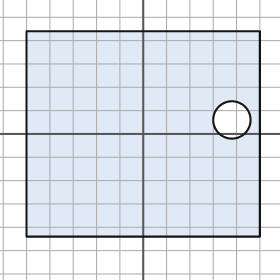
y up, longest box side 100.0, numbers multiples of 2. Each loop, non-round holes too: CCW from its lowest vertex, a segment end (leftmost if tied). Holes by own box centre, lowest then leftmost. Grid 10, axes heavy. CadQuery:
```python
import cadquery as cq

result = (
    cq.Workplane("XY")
    .moveTo(-50.0, -44.0)
    .lineTo(50.0, -44.0)
    .lineTo(50.0, 44.0)
    .lineTo(-50.0, 44.0)
    .close()
    .moveTo(38.0, 6.0)
    .circle(8.0)
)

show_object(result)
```